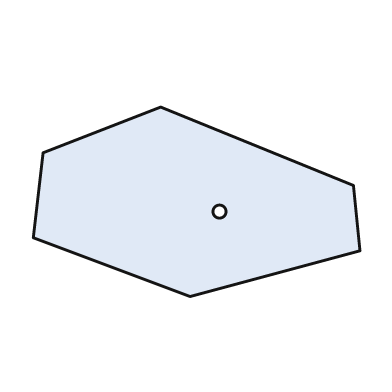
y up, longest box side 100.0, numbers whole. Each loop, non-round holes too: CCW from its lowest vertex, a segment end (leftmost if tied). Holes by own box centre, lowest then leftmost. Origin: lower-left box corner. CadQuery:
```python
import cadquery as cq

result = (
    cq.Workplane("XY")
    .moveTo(48.0, 0.0)
    .lineTo(100.0, 14.0)
    .lineTo(98.0, 34.0)
    .lineTo(39.0, 58.0)
    .lineTo(3.0, 44.0)
    .lineTo(0.0, 18.0)
    .close()
    .moveTo(57.0, 26.0)
    .circle(2.0)
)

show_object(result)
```